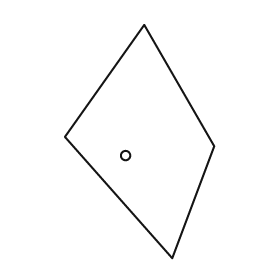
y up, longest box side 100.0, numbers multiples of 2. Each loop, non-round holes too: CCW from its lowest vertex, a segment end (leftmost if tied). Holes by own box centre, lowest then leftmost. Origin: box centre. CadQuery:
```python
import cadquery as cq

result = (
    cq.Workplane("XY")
    .moveTo(14.0, -50.0)
    .lineTo(32.0, -2.0)
    .lineTo(2.0, 50.0)
    .lineTo(-32.0, 2.0)
    .close()
    .moveTo(-6.0, -6.0)
    .circle(2.0)
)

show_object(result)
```